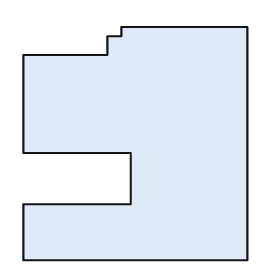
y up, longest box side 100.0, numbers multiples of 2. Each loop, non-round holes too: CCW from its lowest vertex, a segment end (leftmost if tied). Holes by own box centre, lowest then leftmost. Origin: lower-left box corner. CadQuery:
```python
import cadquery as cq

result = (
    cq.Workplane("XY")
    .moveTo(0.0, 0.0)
    .lineTo(96.0, 0.0)
    .lineTo(96.0, 100.0)
    .lineTo(42.0, 100.0)
    .lineTo(42.0, 96.0)
    .lineTo(36.0, 96.0)
    .lineTo(36.0, 88.0)
    .lineTo(0.0, 88.0)
    .lineTo(0.0, 46.0)
    .lineTo(46.0, 46.0)
    .lineTo(46.0, 24.0)
    .lineTo(0.0, 24.0)
    .close()
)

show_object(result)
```